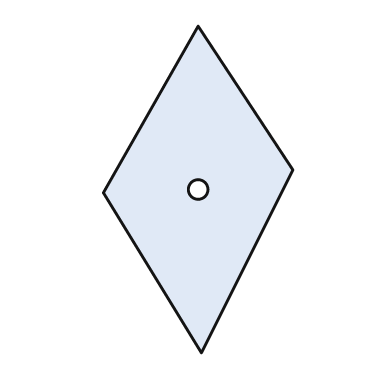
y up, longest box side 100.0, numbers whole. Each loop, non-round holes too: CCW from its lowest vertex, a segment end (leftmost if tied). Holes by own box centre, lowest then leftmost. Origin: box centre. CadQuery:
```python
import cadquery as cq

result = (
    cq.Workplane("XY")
    .moveTo(1.0, -50.0)
    .lineTo(29.0, 6.0)
    .lineTo(0.0, 50.0)
    .lineTo(-29.0, -1.0)
    .close()
    .moveTo(0.0, 0.0)
    .circle(3.0)
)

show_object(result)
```